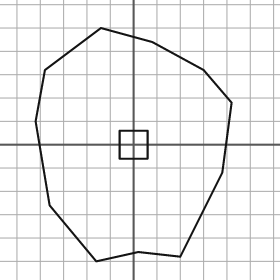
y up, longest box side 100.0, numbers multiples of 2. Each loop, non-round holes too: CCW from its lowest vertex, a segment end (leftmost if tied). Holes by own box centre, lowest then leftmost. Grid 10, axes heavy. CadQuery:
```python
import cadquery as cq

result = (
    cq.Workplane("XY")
    .moveTo(-16.0, -50.0)
    .lineTo(2.0, -46.0)
    .lineTo(20.0, -48.0)
    .lineTo(38.0, -12.0)
    .lineTo(42.0, 18.0)
    .lineTo(30.0, 32.0)
    .lineTo(8.0, 44.0)
    .lineTo(-14.0, 50.0)
    .lineTo(-38.0, 32.0)
    .lineTo(-42.0, 10.0)
    .lineTo(-36.0, -26.0)
    .close()
    .moveTo(-6.0, -6.0)
    .lineTo(6.0, -6.0)
    .lineTo(6.0, 6.0)
    .lineTo(-6.0, 6.0)
    .close()
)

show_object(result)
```